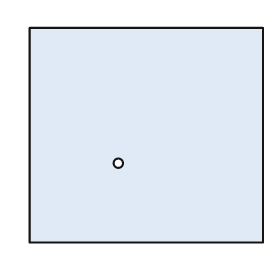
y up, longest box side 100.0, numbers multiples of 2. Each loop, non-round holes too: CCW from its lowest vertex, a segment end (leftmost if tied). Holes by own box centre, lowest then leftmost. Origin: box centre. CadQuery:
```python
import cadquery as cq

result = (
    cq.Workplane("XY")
    .moveTo(-50.0, -46.0)
    .lineTo(50.0, -46.0)
    .lineTo(50.0, 46.0)
    .lineTo(-50.0, 46.0)
    .close()
    .moveTo(-12.0, -12.0)
    .circle(2.0)
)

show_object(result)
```